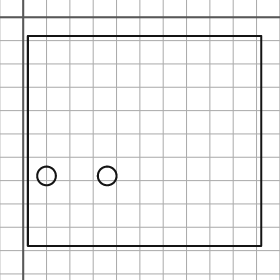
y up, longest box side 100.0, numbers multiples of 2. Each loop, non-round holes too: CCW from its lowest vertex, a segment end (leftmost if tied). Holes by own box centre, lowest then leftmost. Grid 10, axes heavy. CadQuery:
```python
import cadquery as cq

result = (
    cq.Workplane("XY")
    .moveTo(2.0, -98.0)
    .lineTo(102.0, -98.0)
    .lineTo(102.0, -8.0)
    .lineTo(2.0, -8.0)
    .close()
    .moveTo(10.0, -68.0)
    .circle(4.0)
    .moveTo(36.0, -68.0)
    .circle(4.0)
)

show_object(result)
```